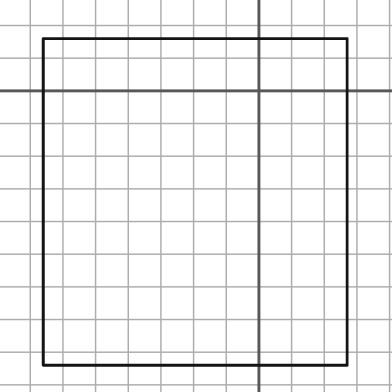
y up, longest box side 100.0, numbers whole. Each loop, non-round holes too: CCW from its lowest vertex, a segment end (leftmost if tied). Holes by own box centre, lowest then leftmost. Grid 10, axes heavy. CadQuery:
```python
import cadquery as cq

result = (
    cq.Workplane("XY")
    .moveTo(-66.0, -84.0)
    .lineTo(27.0, -84.0)
    .lineTo(27.0, 16.0)
    .lineTo(-66.0, 16.0)
    .close()
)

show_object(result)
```